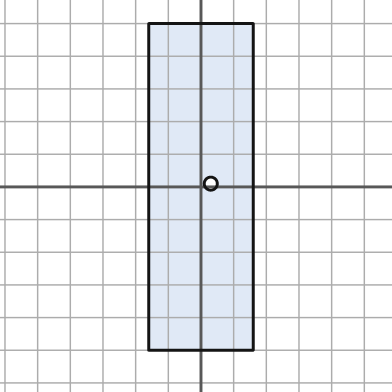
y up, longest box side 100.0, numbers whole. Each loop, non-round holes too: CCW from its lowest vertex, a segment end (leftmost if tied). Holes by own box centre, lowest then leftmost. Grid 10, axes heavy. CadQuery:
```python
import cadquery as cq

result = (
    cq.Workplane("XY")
    .moveTo(-16.0, -50.0)
    .lineTo(16.0, -50.0)
    .lineTo(16.0, 50.0)
    .lineTo(-16.0, 50.0)
    .close()
    .moveTo(3.0, 1.0)
    .circle(2.0)
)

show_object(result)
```